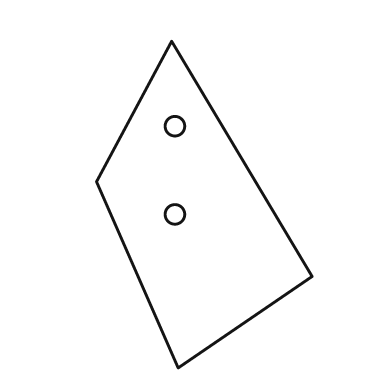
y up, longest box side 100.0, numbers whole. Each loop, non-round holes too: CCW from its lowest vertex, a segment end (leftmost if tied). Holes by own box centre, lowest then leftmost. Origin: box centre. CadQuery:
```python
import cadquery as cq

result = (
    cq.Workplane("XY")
    .moveTo(-8.0, -50.0)
    .lineTo(33.0, -22.0)
    .lineTo(-10.0, 50.0)
    .lineTo(-33.0, 7.0)
    .close()
    .moveTo(-9.0, -3.0)
    .circle(3.0)
    .moveTo(-9.0, 24.0)
    .circle(3.0)
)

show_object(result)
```